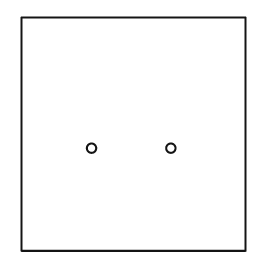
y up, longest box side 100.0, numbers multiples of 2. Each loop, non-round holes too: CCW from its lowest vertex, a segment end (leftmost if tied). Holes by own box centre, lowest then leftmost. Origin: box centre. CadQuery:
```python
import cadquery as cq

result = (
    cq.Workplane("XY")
    .moveTo(-48.0, -50.0)
    .lineTo(48.0, -50.0)
    .lineTo(48.0, 50.0)
    .lineTo(-48.0, 50.0)
    .close()
    .moveTo(-18.0, -6.0)
    .circle(2.0)
    .moveTo(16.0, -6.0)
    .circle(2.0)
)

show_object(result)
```